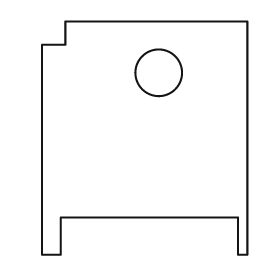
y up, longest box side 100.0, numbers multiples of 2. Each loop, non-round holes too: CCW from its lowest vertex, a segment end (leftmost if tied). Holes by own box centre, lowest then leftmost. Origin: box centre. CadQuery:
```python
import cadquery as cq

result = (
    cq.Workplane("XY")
    .moveTo(-44.0, -50.0)
    .lineTo(-36.0, -50.0)
    .lineTo(-36.0, -34.0)
    .lineTo(40.0, -34.0)
    .lineTo(40.0, -50.0)
    .lineTo(44.0, -50.0)
    .lineTo(44.0, 50.0)
    .lineTo(-34.0, 50.0)
    .lineTo(-34.0, 40.0)
    .lineTo(-44.0, 40.0)
    .close()
    .moveTo(6.0, 28.0)
    .circle(10.0)
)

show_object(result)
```